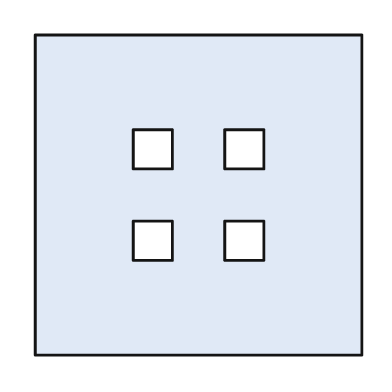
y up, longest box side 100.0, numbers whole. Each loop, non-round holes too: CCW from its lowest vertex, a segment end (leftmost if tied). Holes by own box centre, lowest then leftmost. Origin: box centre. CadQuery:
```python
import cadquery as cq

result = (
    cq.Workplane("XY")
    .moveTo(-50.0, -49.0)
    .lineTo(50.0, -49.0)
    .lineTo(50.0, 49.0)
    .lineTo(-50.0, 49.0)
    .close()
    .moveTo(-20.0, -20.0)
    .lineTo(-8.0, -20.0)
    .lineTo(-8.0, -8.0)
    .lineTo(-20.0, -8.0)
    .close()
    .moveTo(8.0, -20.0)
    .lineTo(20.0, -20.0)
    .lineTo(20.0, -8.0)
    .lineTo(8.0, -8.0)
    .close()
    .moveTo(-20.0, 8.0)
    .lineTo(-8.0, 8.0)
    .lineTo(-8.0, 20.0)
    .lineTo(-20.0, 20.0)
    .close()
    .moveTo(8.0, 8.0)
    .lineTo(20.0, 8.0)
    .lineTo(20.0, 20.0)
    .lineTo(8.0, 20.0)
    .close()
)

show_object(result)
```